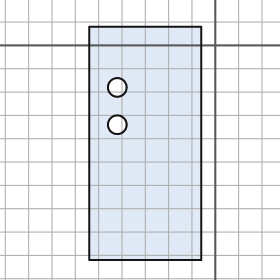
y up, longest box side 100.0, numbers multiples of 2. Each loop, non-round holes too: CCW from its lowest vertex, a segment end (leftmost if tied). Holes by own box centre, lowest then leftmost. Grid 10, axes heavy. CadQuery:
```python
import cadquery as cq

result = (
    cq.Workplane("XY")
    .moveTo(-54.0, -92.0)
    .lineTo(-6.0, -92.0)
    .lineTo(-6.0, 8.0)
    .lineTo(-54.0, 8.0)
    .close()
    .moveTo(-42.0, -34.0)
    .circle(4.0)
    .moveTo(-42.0, -18.0)
    .circle(4.0)
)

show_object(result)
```